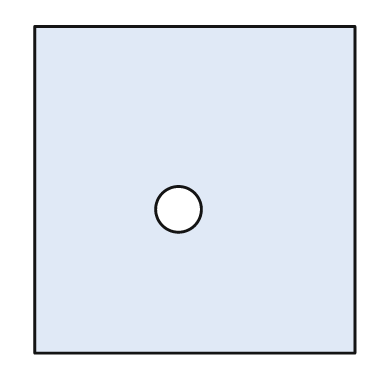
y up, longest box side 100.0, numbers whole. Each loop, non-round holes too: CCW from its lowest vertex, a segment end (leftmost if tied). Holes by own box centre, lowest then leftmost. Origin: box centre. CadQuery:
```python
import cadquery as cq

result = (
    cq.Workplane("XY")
    .moveTo(-49.0, -50.0)
    .lineTo(49.0, -50.0)
    .lineTo(49.0, 50.0)
    .lineTo(-49.0, 50.0)
    .close()
    .moveTo(-5.0, -6.0)
    .circle(7.0)
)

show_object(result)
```